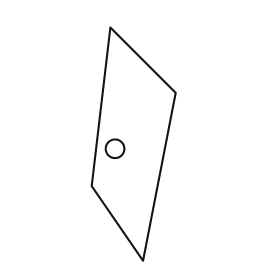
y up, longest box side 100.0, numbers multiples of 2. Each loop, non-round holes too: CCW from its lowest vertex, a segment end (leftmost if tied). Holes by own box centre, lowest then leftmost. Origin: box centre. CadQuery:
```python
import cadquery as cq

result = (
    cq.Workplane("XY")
    .moveTo(4.0, -50.0)
    .lineTo(18.0, 22.0)
    .lineTo(-10.0, 50.0)
    .lineTo(-18.0, -18.0)
    .close()
    .moveTo(-8.0, -2.0)
    .circle(4.0)
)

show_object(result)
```